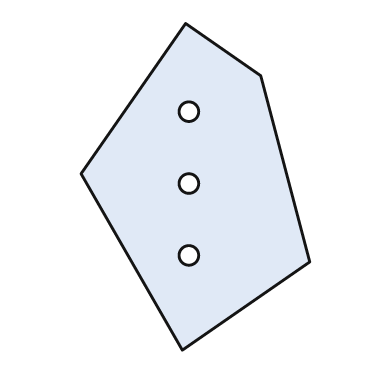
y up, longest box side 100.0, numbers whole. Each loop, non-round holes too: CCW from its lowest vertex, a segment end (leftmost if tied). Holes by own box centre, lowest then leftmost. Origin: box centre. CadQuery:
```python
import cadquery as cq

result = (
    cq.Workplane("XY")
    .moveTo(-4.0, -50.0)
    .lineTo(35.0, -23.0)
    .lineTo(20.0, 34.0)
    .lineTo(-3.0, 50.0)
    .lineTo(-35.0, 4.0)
    .close()
    .moveTo(-2.0, -21.0)
    .circle(3.0)
    .moveTo(-2.0, 1.0)
    .circle(3.0)
    .moveTo(-2.0, 23.0)
    .circle(3.0)
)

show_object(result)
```